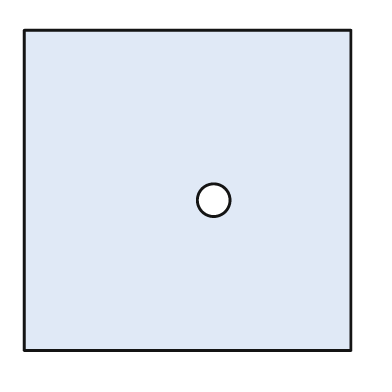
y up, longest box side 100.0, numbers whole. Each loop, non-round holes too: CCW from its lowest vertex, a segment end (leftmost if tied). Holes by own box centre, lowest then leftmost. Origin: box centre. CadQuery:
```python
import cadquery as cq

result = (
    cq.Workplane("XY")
    .moveTo(-50.0, -49.0)
    .lineTo(50.0, -49.0)
    .lineTo(50.0, 49.0)
    .lineTo(-50.0, 49.0)
    .close()
    .moveTo(8.0, -3.0)
    .circle(5.0)
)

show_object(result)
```